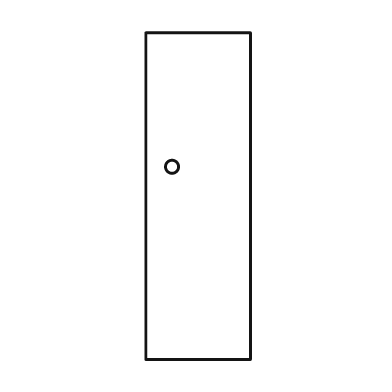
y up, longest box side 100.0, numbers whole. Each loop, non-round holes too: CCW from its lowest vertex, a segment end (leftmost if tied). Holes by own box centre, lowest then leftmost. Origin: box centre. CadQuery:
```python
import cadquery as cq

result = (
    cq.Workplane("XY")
    .moveTo(-16.0, -50.0)
    .lineTo(16.0, -50.0)
    .lineTo(16.0, 50.0)
    .lineTo(-16.0, 50.0)
    .close()
    .moveTo(-8.0, 9.0)
    .circle(2.0)
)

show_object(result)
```